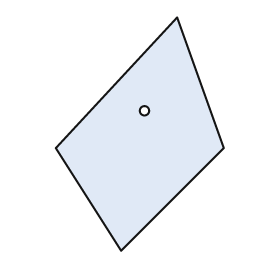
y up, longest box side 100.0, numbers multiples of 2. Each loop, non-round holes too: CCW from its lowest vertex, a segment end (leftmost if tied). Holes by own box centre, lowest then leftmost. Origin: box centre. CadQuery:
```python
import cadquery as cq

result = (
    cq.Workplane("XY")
    .moveTo(-8.0, -50.0)
    .lineTo(36.0, -6.0)
    .lineTo(16.0, 50.0)
    .lineTo(-36.0, -6.0)
    .close()
    .moveTo(2.0, 10.0)
    .circle(2.0)
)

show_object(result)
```